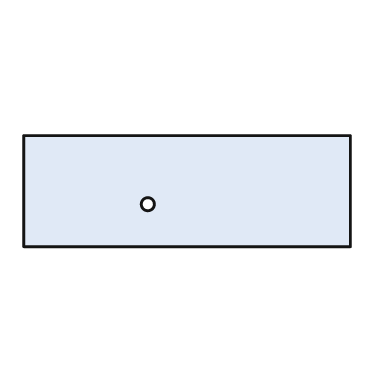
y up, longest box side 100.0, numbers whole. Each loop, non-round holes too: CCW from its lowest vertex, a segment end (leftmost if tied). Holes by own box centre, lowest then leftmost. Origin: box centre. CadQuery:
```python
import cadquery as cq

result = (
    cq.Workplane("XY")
    .moveTo(-50.0, -17.0)
    .lineTo(50.0, -17.0)
    .lineTo(50.0, 17.0)
    .lineTo(-50.0, 17.0)
    .close()
    .moveTo(-12.0, -4.0)
    .circle(2.0)
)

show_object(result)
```